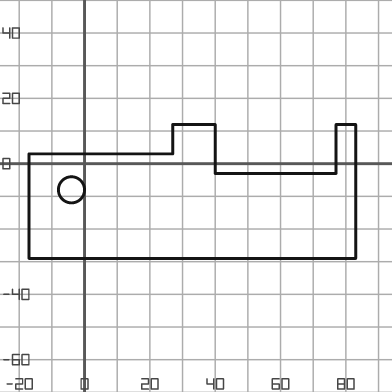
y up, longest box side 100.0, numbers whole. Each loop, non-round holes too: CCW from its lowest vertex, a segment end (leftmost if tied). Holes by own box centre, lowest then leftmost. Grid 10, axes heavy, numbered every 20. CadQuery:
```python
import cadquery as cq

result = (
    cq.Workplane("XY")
    .moveTo(-17.0, -29.0)
    .lineTo(83.0, -29.0)
    .lineTo(83.0, 12.0)
    .lineTo(77.0, 12.0)
    .lineTo(77.0, -3.0)
    .lineTo(40.0, -3.0)
    .lineTo(40.0, 12.0)
    .lineTo(27.0, 12.0)
    .lineTo(27.0, 3.0)
    .lineTo(-17.0, 3.0)
    .close()
    .moveTo(-4.0, -8.0)
    .circle(4.0)
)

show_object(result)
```